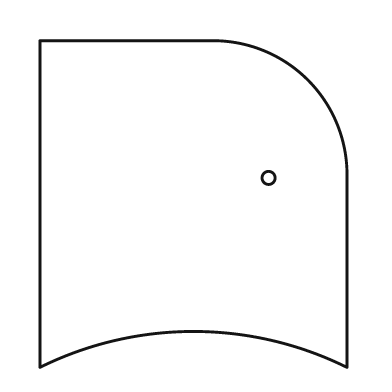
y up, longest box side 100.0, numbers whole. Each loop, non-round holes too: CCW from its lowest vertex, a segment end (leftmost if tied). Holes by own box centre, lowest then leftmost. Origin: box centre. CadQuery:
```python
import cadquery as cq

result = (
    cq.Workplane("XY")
    .moveTo(-47.0, -50.0)
    .threePointArc((0.0, -39.0), (47.0, -50.0))
    .lineTo(47.0, 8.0)
    .threePointArc((35.0, 38.0), (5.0, 50.0))
    .lineTo(-47.0, 50.0)
    .close()
    .moveTo(23.0, 8.0)
    .circle(2.0)
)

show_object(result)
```